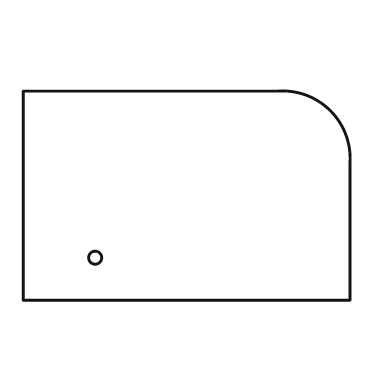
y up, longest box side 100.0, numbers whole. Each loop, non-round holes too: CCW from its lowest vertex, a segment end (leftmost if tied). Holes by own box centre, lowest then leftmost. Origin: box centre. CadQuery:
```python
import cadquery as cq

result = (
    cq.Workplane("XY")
    .moveTo(-50.0, -32.0)
    .lineTo(50.0, -32.0)
    .lineTo(50.0, 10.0)
    .threePointArc((44.0, 26.0), (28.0, 32.0))
    .lineTo(-50.0, 32.0)
    .close()
    .moveTo(-28.0, -19.0)
    .circle(2.0)
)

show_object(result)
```